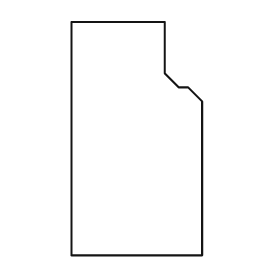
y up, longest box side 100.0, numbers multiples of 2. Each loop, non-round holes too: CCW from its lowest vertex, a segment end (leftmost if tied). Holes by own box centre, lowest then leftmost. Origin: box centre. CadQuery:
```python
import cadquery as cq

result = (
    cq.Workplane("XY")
    .moveTo(-28.0, -50.0)
    .lineTo(28.0, -50.0)
    .lineTo(28.0, 16.0)
    .lineTo(22.0, 22.0)
    .lineTo(18.0, 22.0)
    .lineTo(12.0, 28.0)
    .lineTo(12.0, 50.0)
    .lineTo(-28.0, 50.0)
    .close()
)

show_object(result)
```